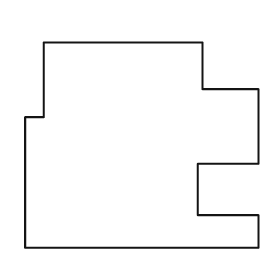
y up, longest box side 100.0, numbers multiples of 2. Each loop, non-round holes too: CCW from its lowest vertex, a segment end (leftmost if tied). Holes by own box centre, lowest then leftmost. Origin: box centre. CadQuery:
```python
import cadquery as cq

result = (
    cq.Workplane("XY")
    .moveTo(-50.0, -44.0)
    .lineTo(50.0, -44.0)
    .lineTo(50.0, -30.0)
    .lineTo(24.0, -30.0)
    .lineTo(24.0, -8.0)
    .lineTo(50.0, -8.0)
    .lineTo(50.0, 24.0)
    .lineTo(26.0, 24.0)
    .lineTo(26.0, 44.0)
    .lineTo(-42.0, 44.0)
    .lineTo(-42.0, 12.0)
    .lineTo(-50.0, 12.0)
    .close()
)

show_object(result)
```